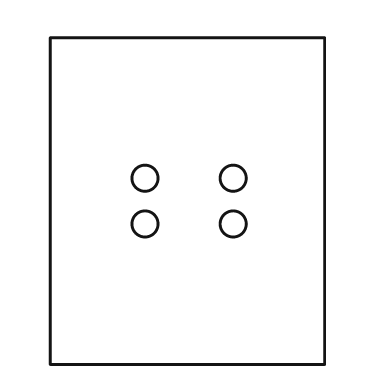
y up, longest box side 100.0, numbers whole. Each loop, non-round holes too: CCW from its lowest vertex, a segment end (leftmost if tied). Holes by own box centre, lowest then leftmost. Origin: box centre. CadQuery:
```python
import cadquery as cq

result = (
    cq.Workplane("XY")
    .moveTo(-42.0, -50.0)
    .lineTo(42.0, -50.0)
    .lineTo(42.0, 50.0)
    .lineTo(-42.0, 50.0)
    .close()
    .moveTo(-13.0, -7.0)
    .circle(4.0)
    .moveTo(14.0, -7.0)
    .circle(4.0)
    .moveTo(-13.0, 7.0)
    .circle(4.0)
    .moveTo(14.0, 7.0)
    .circle(4.0)
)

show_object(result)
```